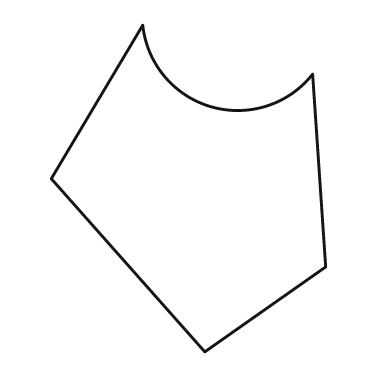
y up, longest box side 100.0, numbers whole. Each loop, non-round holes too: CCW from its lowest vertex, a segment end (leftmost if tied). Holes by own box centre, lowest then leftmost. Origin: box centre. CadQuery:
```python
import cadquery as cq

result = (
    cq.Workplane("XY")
    .moveTo(5.0, -50.0)
    .lineTo(42.0, -24.0)
    .lineTo(38.0, 35.0)
    .threePointArc((7.0, 25.0), (-14.0, 50.0))
    .lineTo(-42.0, 3.0)
    .close()
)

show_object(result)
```